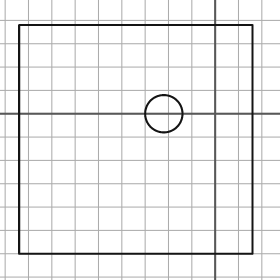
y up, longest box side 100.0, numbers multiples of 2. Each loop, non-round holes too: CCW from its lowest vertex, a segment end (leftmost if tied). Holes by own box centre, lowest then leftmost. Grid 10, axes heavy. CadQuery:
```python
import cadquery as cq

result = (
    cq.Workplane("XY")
    .moveTo(-84.0, -60.0)
    .lineTo(16.0, -60.0)
    .lineTo(16.0, 38.0)
    .lineTo(-84.0, 38.0)
    .close()
    .moveTo(-22.0, 0.0)
    .circle(8.0)
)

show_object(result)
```